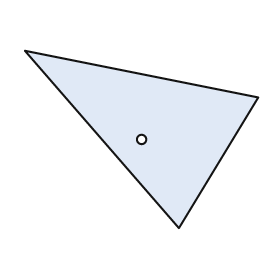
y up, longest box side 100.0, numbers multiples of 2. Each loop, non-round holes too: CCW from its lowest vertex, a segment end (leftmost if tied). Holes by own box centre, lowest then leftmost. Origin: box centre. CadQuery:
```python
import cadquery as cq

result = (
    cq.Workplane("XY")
    .moveTo(16.0, -38.0)
    .lineTo(50.0, 18.0)
    .lineTo(-50.0, 38.0)
    .close()
    .moveTo(0.0, 0.0)
    .circle(2.0)
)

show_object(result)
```